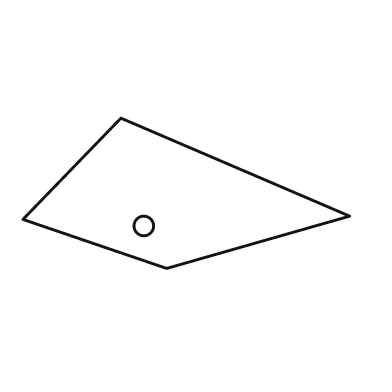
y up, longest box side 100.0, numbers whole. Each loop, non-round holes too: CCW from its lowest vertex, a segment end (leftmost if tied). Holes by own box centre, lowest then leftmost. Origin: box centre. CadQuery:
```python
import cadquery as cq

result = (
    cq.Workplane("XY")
    .moveTo(-6.0, -23.0)
    .lineTo(50.0, -7.0)
    .lineTo(-20.0, 23.0)
    .lineTo(-50.0, -8.0)
    .close()
    .moveTo(-13.0, -10.0)
    .circle(3.0)
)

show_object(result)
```